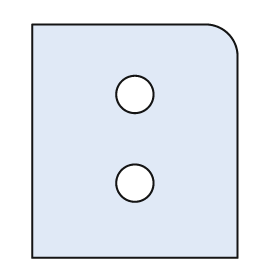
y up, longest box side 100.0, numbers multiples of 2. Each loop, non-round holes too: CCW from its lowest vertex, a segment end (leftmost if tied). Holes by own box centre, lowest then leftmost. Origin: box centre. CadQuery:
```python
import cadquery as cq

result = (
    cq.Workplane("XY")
    .moveTo(-44.0, -50.0)
    .lineTo(44.0, -50.0)
    .lineTo(44.0, 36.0)
    .threePointArc((40.0, 46.0), (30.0, 50.0))
    .lineTo(-44.0, 50.0)
    .close()
    .moveTo(0.0, -18.0)
    .circle(8.0)
    .moveTo(0.0, 20.0)
    .circle(8.0)
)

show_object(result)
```